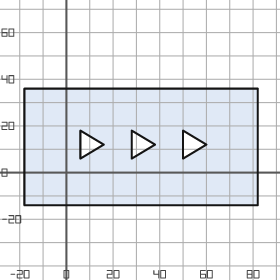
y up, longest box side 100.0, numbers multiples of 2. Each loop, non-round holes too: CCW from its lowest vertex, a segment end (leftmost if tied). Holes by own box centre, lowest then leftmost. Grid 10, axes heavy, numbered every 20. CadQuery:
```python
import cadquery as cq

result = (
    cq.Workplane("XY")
    .moveTo(-18.0, -14.0)
    .lineTo(82.0, -14.0)
    .lineTo(82.0, 36.0)
    .lineTo(-18.0, 36.0)
    .close()
    .moveTo(6.0, 6.0)
    .lineTo(16.0, 12.0)
    .lineTo(6.0, 18.0)
    .close()
    .moveTo(28.0, 6.0)
    .lineTo(38.0, 12.0)
    .lineTo(28.0, 18.0)
    .close()
    .moveTo(50.0, 6.0)
    .lineTo(60.0, 12.0)
    .lineTo(50.0, 18.0)
    .close()
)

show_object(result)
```